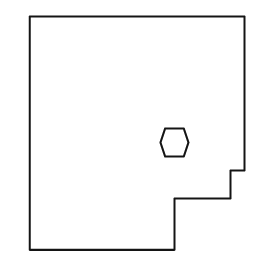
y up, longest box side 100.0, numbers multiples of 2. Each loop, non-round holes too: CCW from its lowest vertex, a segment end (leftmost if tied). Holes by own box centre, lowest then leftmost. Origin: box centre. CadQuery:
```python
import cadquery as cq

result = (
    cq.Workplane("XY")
    .moveTo(-46.0, -50.0)
    .lineTo(16.0, -50.0)
    .lineTo(16.0, -28.0)
    .lineTo(40.0, -28.0)
    .lineTo(40.0, -16.0)
    .lineTo(46.0, -16.0)
    .lineTo(46.0, 50.0)
    .lineTo(-46.0, 50.0)
    .close()
    .moveTo(12.0, -10.0)
    .lineTo(20.0, -10.0)
    .lineTo(22.0, -4.0)
    .lineTo(20.0, 2.0)
    .lineTo(12.0, 2.0)
    .lineTo(10.0, -4.0)
    .close()
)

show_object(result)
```